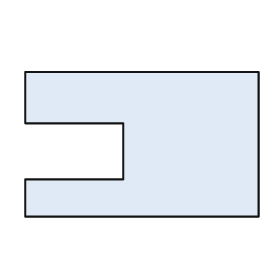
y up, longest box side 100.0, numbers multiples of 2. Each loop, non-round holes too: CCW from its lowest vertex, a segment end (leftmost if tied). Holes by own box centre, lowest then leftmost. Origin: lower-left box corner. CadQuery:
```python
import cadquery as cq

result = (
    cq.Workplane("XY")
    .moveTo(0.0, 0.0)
    .lineTo(100.0, 0.0)
    .lineTo(100.0, 62.0)
    .lineTo(0.0, 62.0)
    .lineTo(0.0, 40.0)
    .lineTo(42.0, 40.0)
    .lineTo(42.0, 16.0)
    .lineTo(0.0, 16.0)
    .close()
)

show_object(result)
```